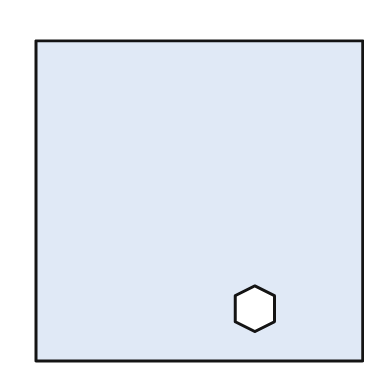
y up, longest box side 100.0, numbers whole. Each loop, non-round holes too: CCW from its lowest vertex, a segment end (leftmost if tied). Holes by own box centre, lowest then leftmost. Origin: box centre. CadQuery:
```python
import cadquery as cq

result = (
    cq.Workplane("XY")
    .moveTo(-50.0, -49.0)
    .lineTo(50.0, -49.0)
    .lineTo(50.0, 49.0)
    .lineTo(-50.0, 49.0)
    .close()
    .moveTo(17.0, -40.0)
    .lineTo(23.0, -37.0)
    .lineTo(23.0, -29.0)
    .lineTo(17.0, -26.0)
    .lineTo(11.0, -29.0)
    .lineTo(11.0, -37.0)
    .close()
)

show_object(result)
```